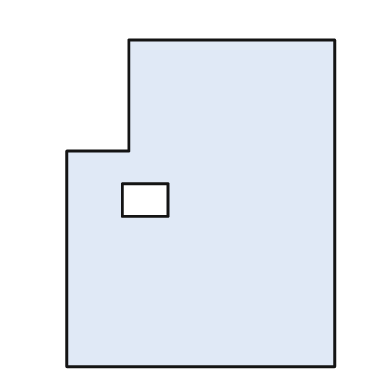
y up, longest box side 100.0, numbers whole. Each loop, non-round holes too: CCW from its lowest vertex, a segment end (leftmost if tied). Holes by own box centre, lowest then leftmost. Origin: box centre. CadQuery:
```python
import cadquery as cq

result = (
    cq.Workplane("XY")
    .moveTo(-41.0, -50.0)
    .lineTo(41.0, -50.0)
    .lineTo(41.0, 50.0)
    .lineTo(-22.0, 50.0)
    .lineTo(-22.0, 16.0)
    .lineTo(-41.0, 16.0)
    .close()
    .moveTo(-24.0, -4.0)
    .lineTo(-10.0, -4.0)
    .lineTo(-10.0, 6.0)
    .lineTo(-24.0, 6.0)
    .close()
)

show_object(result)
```